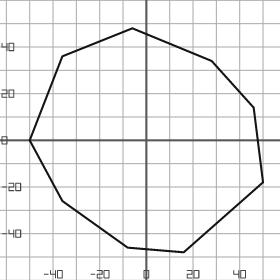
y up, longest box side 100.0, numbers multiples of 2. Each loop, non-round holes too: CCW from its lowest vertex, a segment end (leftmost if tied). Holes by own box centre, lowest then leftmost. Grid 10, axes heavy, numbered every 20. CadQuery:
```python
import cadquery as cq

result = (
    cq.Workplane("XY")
    .moveTo(16.0, -48.0)
    .lineTo(50.0, -18.0)
    .lineTo(46.0, 14.0)
    .lineTo(28.0, 34.0)
    .lineTo(-6.0, 48.0)
    .lineTo(-36.0, 36.0)
    .lineTo(-50.0, 0.0)
    .lineTo(-36.0, -26.0)
    .lineTo(-8.0, -46.0)
    .close()
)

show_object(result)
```